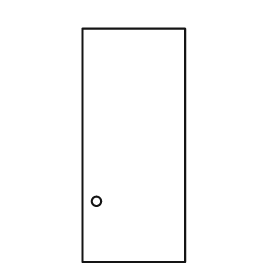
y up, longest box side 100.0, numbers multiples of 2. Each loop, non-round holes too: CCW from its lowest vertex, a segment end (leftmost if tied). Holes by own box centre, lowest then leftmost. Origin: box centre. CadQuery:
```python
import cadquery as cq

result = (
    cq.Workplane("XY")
    .moveTo(-22.0, -50.0)
    .lineTo(22.0, -50.0)
    .lineTo(22.0, 50.0)
    .lineTo(-22.0, 50.0)
    .close()
    .moveTo(-16.0, -24.0)
    .circle(2.0)
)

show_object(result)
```